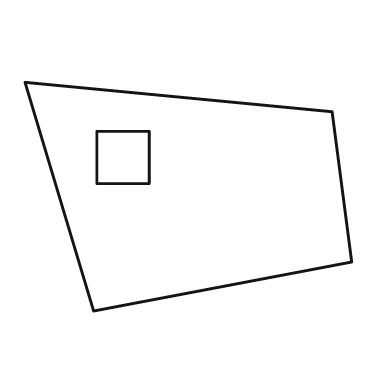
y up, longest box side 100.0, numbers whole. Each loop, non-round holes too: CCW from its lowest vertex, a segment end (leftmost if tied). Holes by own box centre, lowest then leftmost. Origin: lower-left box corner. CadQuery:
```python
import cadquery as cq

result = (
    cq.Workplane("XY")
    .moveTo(21.0, 0.0)
    .lineTo(100.0, 15.0)
    .lineTo(94.0, 61.0)
    .lineTo(0.0, 70.0)
    .close()
    .moveTo(22.0, 39.0)
    .lineTo(38.0, 39.0)
    .lineTo(38.0, 55.0)
    .lineTo(22.0, 55.0)
    .close()
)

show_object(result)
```